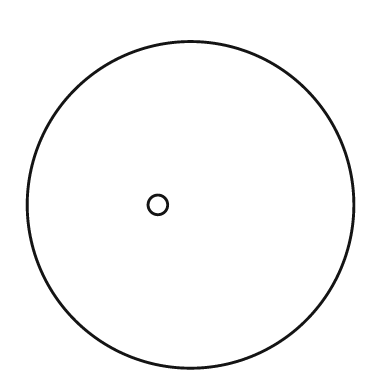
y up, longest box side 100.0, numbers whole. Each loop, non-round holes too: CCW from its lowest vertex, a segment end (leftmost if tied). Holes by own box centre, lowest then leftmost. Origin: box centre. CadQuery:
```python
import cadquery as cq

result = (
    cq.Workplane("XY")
    .moveTo(0.0, 0.0)
    .circle(50.0)
    .moveTo(-10.0, 0.0)
    .circle(3.0)
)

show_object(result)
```